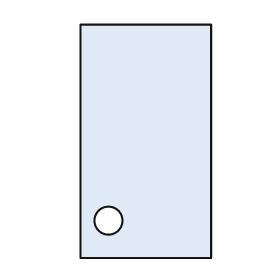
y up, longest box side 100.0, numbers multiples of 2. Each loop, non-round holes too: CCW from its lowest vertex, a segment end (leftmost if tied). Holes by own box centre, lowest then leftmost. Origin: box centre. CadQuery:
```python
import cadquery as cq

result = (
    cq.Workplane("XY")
    .moveTo(-28.0, -50.0)
    .lineTo(28.0, -50.0)
    .lineTo(28.0, 50.0)
    .lineTo(-28.0, 50.0)
    .close()
    .moveTo(-16.0, -34.0)
    .circle(6.0)
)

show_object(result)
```